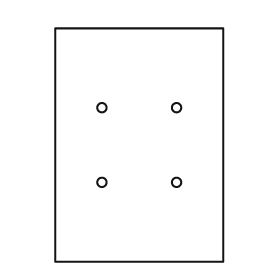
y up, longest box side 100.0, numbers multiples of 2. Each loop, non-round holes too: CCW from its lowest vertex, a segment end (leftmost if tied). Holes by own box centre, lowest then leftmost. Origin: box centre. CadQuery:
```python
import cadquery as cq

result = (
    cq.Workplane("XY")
    .moveTo(-36.0, -50.0)
    .lineTo(36.0, -50.0)
    .lineTo(36.0, 50.0)
    .lineTo(-36.0, 50.0)
    .close()
    .moveTo(-16.0, -16.0)
    .circle(2.0)
    .moveTo(16.0, -16.0)
    .circle(2.0)
    .moveTo(-16.0, 16.0)
    .circle(2.0)
    .moveTo(16.0, 16.0)
    .circle(2.0)
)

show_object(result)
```